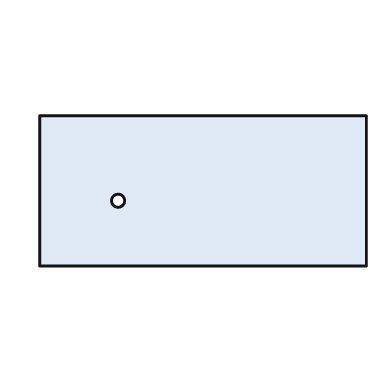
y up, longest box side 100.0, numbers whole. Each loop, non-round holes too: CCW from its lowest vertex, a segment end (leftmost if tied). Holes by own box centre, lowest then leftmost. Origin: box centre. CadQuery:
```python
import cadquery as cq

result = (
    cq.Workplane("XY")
    .moveTo(-50.0, -23.0)
    .lineTo(50.0, -23.0)
    .lineTo(50.0, 23.0)
    .lineTo(-50.0, 23.0)
    .close()
    .moveTo(-26.0, -3.0)
    .circle(2.0)
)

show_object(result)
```